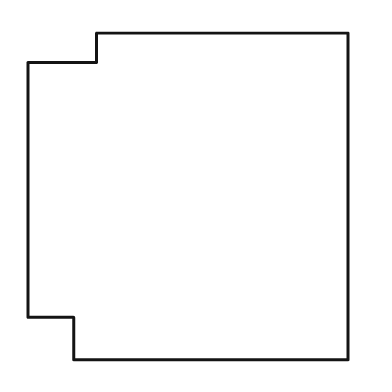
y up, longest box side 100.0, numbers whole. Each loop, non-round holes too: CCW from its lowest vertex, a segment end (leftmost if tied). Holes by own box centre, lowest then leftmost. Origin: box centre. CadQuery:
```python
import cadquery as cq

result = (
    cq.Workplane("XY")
    .moveTo(-35.0, -50.0)
    .lineTo(49.0, -50.0)
    .lineTo(49.0, 50.0)
    .lineTo(-28.0, 50.0)
    .lineTo(-28.0, 41.0)
    .lineTo(-49.0, 41.0)
    .lineTo(-49.0, -37.0)
    .lineTo(-35.0, -37.0)
    .close()
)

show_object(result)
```